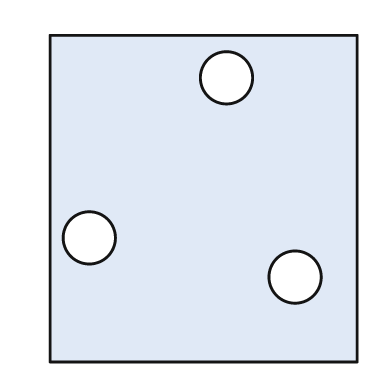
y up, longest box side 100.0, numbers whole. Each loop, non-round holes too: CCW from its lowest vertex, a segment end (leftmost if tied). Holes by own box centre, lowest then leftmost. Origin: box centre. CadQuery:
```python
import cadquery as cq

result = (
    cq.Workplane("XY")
    .moveTo(-47.0, -50.0)
    .lineTo(47.0, -50.0)
    .lineTo(47.0, 50.0)
    .lineTo(-47.0, 50.0)
    .close()
    .moveTo(28.0, -24.0)
    .circle(8.0)
    .moveTo(-35.0, -12.0)
    .circle(8.0)
    .moveTo(7.0, 37.0)
    .circle(8.0)
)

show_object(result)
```